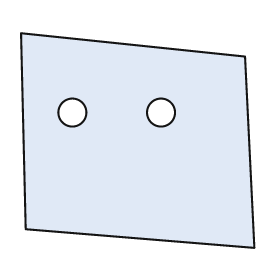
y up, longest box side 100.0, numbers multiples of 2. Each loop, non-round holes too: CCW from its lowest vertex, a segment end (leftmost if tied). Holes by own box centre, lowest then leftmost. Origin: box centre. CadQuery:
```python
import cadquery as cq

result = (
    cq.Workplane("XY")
    .moveTo(50.0, -46.0)
    .lineTo(46.0, 36.0)
    .lineTo(-50.0, 46.0)
    .lineTo(-48.0, -38.0)
    .close()
    .moveTo(-28.0, 12.0)
    .circle(6.0)
    .moveTo(10.0, 12.0)
    .circle(6.0)
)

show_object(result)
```